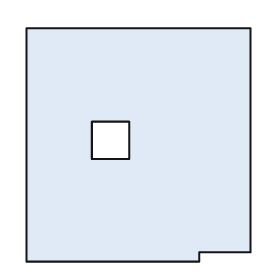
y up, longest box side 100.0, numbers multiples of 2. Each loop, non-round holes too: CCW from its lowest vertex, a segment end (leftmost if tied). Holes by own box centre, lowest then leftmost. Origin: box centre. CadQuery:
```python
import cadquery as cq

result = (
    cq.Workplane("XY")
    .moveTo(-48.0, -50.0)
    .lineTo(26.0, -50.0)
    .lineTo(26.0, -46.0)
    .lineTo(48.0, -46.0)
    .lineTo(48.0, 50.0)
    .lineTo(-48.0, 50.0)
    .close()
    .moveTo(-20.0, -6.0)
    .lineTo(-4.0, -6.0)
    .lineTo(-4.0, 10.0)
    .lineTo(-20.0, 10.0)
    .close()
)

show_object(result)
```